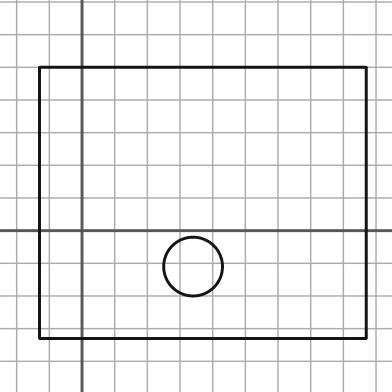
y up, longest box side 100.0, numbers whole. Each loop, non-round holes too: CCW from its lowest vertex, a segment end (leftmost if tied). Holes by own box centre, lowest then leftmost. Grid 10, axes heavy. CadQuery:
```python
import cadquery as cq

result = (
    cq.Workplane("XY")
    .moveTo(-13.0, -33.0)
    .lineTo(87.0, -33.0)
    .lineTo(87.0, 50.0)
    .lineTo(-13.0, 50.0)
    .close()
    .moveTo(34.0, -11.0)
    .circle(9.0)
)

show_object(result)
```